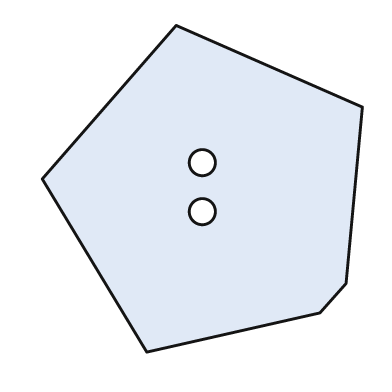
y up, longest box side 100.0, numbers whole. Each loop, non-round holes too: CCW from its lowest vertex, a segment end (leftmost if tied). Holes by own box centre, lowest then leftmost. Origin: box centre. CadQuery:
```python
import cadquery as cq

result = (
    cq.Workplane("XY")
    .moveTo(-17.0, -50.0)
    .lineTo(36.0, -38.0)
    .lineTo(44.0, -29.0)
    .lineTo(49.0, 25.0)
    .lineTo(-8.0, 50.0)
    .lineTo(-49.0, 3.0)
    .close()
    .moveTo(0.0, -7.0)
    .circle(4.0)
    .moveTo(0.0, 8.0)
    .circle(4.0)
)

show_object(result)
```